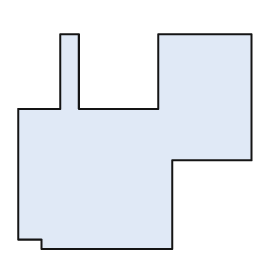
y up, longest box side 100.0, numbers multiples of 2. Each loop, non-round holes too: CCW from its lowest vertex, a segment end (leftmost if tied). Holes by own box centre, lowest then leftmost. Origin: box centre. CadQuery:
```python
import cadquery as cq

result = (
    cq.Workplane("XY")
    .moveTo(-40.0, -46.0)
    .lineTo(16.0, -46.0)
    .lineTo(16.0, -8.0)
    .lineTo(50.0, -8.0)
    .lineTo(50.0, 46.0)
    .lineTo(10.0, 46.0)
    .lineTo(10.0, 14.0)
    .lineTo(-24.0, 14.0)
    .lineTo(-24.0, 46.0)
    .lineTo(-32.0, 46.0)
    .lineTo(-32.0, 14.0)
    .lineTo(-50.0, 14.0)
    .lineTo(-50.0, -42.0)
    .lineTo(-40.0, -42.0)
    .close()
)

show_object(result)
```